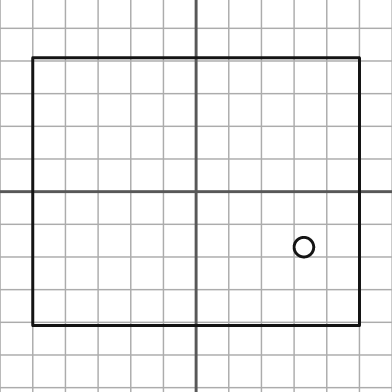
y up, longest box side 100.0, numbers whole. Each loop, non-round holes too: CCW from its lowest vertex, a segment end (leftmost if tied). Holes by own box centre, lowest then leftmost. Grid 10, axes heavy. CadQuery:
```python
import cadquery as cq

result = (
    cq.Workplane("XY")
    .moveTo(-50.0, -41.0)
    .lineTo(50.0, -41.0)
    .lineTo(50.0, 41.0)
    .lineTo(-50.0, 41.0)
    .close()
    .moveTo(33.0, -17.0)
    .circle(3.0)
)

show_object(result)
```